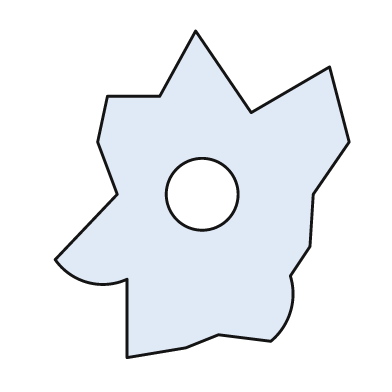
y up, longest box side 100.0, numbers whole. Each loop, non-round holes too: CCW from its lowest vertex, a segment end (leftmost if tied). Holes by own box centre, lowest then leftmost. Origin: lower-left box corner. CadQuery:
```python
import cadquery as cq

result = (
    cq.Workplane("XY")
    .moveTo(22.0, 0.0)
    .lineTo(40.0, 3.0)
    .lineTo(50.0, 7.0)
    .lineTo(66.0, 5.0)
    .threePointArc((72.0, 14.0), (72.0, 25.0))
    .lineTo(78.0, 34.0)
    .lineTo(79.0, 50.0)
    .lineTo(90.0, 66.0)
    .lineTo(84.0, 89.0)
    .lineTo(60.0, 75.0)
    .lineTo(43.0, 100.0)
    .lineTo(32.0, 80.0)
    .lineTo(16.0, 80.0)
    .lineTo(13.0, 66.0)
    .lineTo(19.0, 50.0)
    .lineTo(0.0, 30.0)
    .threePointArc((10.0, 23.0), (22.0, 24.0))
    .close()
    .moveTo(45.0, 50.0)
    .circle(11.0)
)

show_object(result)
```